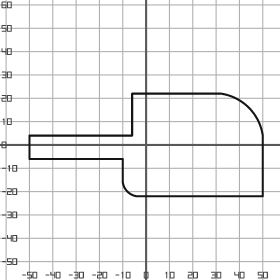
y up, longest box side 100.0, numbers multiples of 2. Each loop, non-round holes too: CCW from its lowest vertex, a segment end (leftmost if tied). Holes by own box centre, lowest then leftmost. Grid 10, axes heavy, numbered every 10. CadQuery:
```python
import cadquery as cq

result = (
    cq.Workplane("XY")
    .moveTo(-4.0, -22.0)
    .lineTo(50.0, -22.0)
    .lineTo(50.0, 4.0)
    .threePointArc((44.0, 16.0), (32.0, 22.0))
    .lineTo(-6.0, 22.0)
    .lineTo(-6.0, 4.0)
    .lineTo(-50.0, 4.0)
    .lineTo(-50.0, -6.0)
    .lineTo(-10.0, -6.0)
    .lineTo(-10.0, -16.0)
    .threePointArc((-8.0, -20.0), (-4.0, -22.0))
    .close()
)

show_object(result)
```